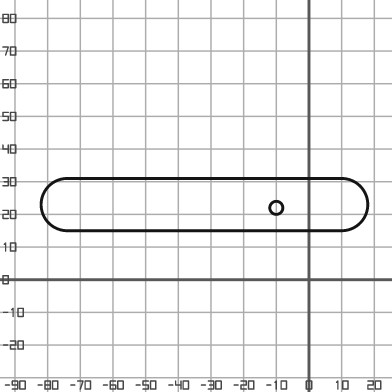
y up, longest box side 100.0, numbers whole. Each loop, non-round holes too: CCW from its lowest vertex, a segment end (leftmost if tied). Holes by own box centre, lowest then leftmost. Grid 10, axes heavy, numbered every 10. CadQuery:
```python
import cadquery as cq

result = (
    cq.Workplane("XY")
    .moveTo(-74.0, 15.0)
    .lineTo(10.0, 15.0)
    .threePointArc((18.0, 23.0), (10.0, 31.0))
    .lineTo(-74.0, 31.0)
    .threePointArc((-82.0, 23.0), (-74.0, 15.0))
    .close()
    .moveTo(-10.0, 22.0)
    .circle(2.0)
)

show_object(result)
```